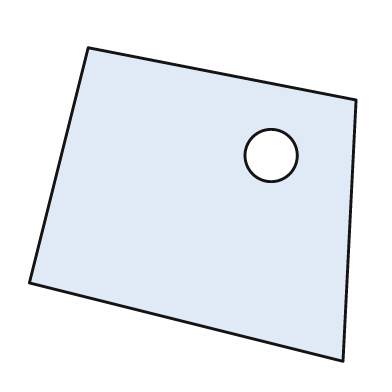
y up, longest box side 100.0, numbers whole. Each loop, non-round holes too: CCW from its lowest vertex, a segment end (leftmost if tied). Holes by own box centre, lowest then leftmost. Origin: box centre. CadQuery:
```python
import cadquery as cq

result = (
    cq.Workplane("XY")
    .moveTo(46.0, -48.0)
    .lineTo(50.0, 32.0)
    .lineTo(-32.0, 48.0)
    .lineTo(-50.0, -24.0)
    .close()
    .moveTo(24.0, 15.0)
    .circle(8.0)
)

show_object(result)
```